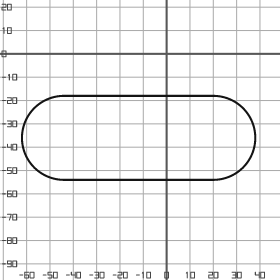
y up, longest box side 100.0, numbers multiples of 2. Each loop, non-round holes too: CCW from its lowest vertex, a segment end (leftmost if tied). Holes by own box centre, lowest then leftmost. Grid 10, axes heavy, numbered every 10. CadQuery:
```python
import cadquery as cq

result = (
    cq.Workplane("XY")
    .moveTo(-44.0, -54.0)
    .lineTo(20.0, -54.0)
    .threePointArc((38.0, -36.0), (20.0, -18.0))
    .lineTo(-44.0, -18.0)
    .threePointArc((-62.0, -36.0), (-44.0, -54.0))
    .close()
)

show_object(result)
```